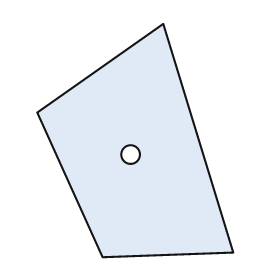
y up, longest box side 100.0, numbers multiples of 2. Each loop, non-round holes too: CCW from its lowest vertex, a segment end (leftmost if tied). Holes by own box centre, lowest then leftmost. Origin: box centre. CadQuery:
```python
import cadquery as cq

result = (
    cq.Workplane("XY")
    .moveTo(-14.0, -50.0)
    .lineTo(42.0, -48.0)
    .lineTo(12.0, 50.0)
    .lineTo(-42.0, 12.0)
    .close()
    .moveTo(-2.0, -6.0)
    .circle(4.0)
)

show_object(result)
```